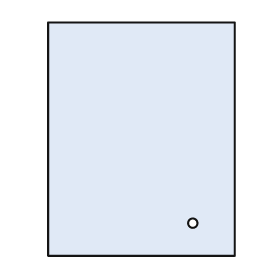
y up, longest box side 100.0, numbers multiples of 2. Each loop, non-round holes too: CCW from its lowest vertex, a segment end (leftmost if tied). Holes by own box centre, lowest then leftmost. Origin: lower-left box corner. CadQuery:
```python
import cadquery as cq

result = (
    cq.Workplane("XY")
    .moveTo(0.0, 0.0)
    .lineTo(80.0, 0.0)
    .lineTo(80.0, 100.0)
    .lineTo(0.0, 100.0)
    .close()
    .moveTo(62.0, 14.0)
    .circle(2.0)
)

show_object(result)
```